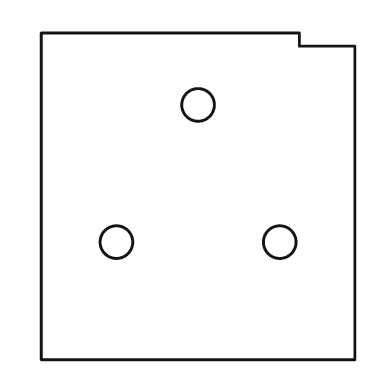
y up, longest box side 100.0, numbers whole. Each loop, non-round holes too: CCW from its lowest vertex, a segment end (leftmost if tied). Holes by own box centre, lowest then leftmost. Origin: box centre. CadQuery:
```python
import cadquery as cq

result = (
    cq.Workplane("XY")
    .moveTo(-48.0, -50.0)
    .lineTo(48.0, -50.0)
    .lineTo(48.0, 46.0)
    .lineTo(31.0, 46.0)
    .lineTo(31.0, 50.0)
    .lineTo(-48.0, 50.0)
    .close()
    .moveTo(-25.0, -14.0)
    .circle(5.0)
    .moveTo(25.0, -14.0)
    .circle(5.0)
    .moveTo(0.0, 28.0)
    .circle(5.0)
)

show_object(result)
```